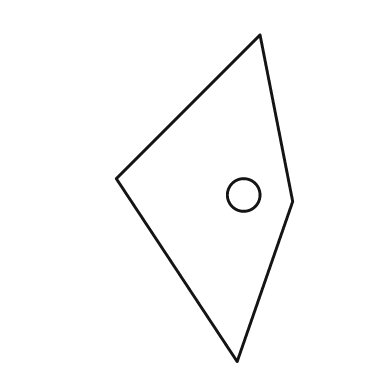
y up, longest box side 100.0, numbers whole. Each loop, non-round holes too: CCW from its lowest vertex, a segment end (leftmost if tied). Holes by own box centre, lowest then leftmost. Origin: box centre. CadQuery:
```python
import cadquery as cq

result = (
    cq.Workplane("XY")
    .moveTo(10.0, -50.0)
    .lineTo(27.0, -1.0)
    .lineTo(17.0, 50.0)
    .lineTo(-27.0, 6.0)
    .close()
    .moveTo(12.0, 1.0)
    .circle(5.0)
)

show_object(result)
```